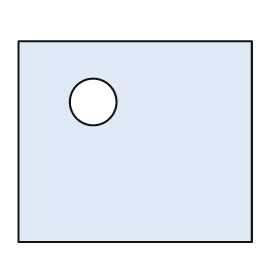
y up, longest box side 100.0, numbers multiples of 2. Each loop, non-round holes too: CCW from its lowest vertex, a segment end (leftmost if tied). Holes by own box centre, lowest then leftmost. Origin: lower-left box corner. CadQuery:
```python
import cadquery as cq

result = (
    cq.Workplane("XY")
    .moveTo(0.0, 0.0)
    .lineTo(100.0, 0.0)
    .lineTo(100.0, 86.0)
    .lineTo(0.0, 86.0)
    .close()
    .moveTo(32.0, 60.0)
    .circle(10.0)
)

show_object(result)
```